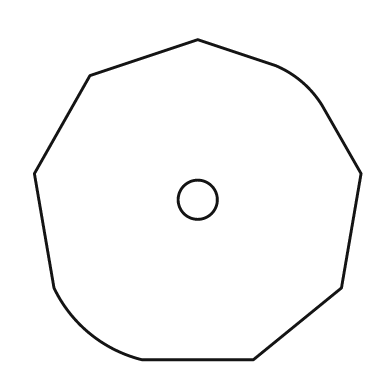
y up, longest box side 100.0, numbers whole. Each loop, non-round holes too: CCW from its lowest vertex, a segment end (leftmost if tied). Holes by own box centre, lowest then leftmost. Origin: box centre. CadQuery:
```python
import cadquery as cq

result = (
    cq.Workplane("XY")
    .moveTo(-17.0, -49.0)
    .lineTo(17.0, -49.0)
    .lineTo(44.0, -27.0)
    .lineTo(50.0, 8.0)
    .lineTo(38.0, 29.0)
    .threePointArc((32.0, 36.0), (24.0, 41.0))
    .lineTo(0.0, 49.0)
    .lineTo(-33.0, 38.0)
    .lineTo(-50.0, 8.0)
    .lineTo(-44.0, -27.0)
    .threePointArc((-33.0, -41.0), (-17.0, -49.0))
    .close()
    .moveTo(0.0, 0.0)
    .circle(6.0)
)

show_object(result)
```